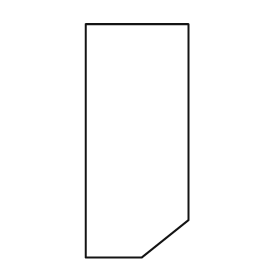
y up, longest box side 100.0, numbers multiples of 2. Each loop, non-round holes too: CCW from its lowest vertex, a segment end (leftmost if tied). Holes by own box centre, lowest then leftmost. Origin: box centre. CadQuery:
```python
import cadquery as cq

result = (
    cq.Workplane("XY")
    .moveTo(-22.0, -50.0)
    .lineTo(2.0, -50.0)
    .lineTo(22.0, -34.0)
    .lineTo(22.0, 50.0)
    .lineTo(-22.0, 50.0)
    .close()
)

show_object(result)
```